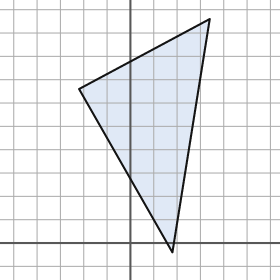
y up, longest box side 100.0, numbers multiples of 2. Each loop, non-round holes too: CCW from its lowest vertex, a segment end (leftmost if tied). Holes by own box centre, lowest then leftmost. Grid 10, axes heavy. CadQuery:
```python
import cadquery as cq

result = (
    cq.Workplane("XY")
    .moveTo(18.0, -4.0)
    .lineTo(34.0, 96.0)
    .lineTo(-22.0, 66.0)
    .close()
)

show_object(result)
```